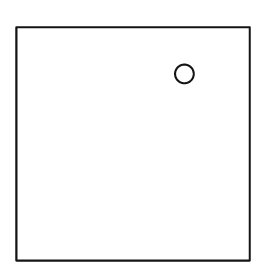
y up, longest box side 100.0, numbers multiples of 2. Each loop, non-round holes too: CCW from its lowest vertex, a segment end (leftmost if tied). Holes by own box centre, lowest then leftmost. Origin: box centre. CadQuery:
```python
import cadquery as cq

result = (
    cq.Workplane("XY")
    .moveTo(-50.0, -50.0)
    .lineTo(50.0, -50.0)
    .lineTo(50.0, 50.0)
    .lineTo(-50.0, 50.0)
    .close()
    .moveTo(22.0, 30.0)
    .circle(4.0)
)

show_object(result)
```